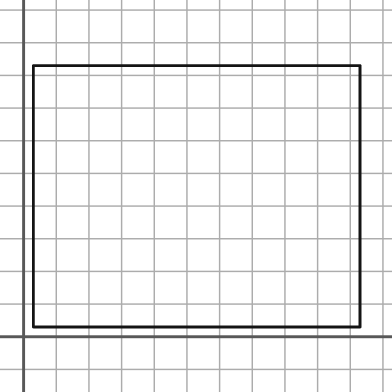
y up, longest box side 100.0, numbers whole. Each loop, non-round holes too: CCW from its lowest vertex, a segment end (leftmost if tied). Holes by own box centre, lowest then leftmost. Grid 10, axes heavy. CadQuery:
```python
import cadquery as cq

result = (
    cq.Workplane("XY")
    .moveTo(3.0, 3.0)
    .lineTo(103.0, 3.0)
    .lineTo(103.0, 83.0)
    .lineTo(3.0, 83.0)
    .close()
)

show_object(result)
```